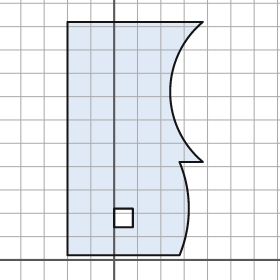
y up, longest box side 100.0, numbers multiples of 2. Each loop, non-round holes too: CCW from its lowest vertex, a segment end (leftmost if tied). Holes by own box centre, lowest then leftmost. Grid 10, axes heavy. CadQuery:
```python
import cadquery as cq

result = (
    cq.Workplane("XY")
    .moveTo(-20.0, 2.0)
    .lineTo(28.0, 2.0)
    .threePointArc((32.0, 22.0), (28.0, 42.0))
    .lineTo(38.0, 42.0)
    .threePointArc((24.0, 72.0), (38.0, 102.0))
    .lineTo(-20.0, 102.0)
    .close()
    .moveTo(0.0, 14.0)
    .lineTo(8.0, 14.0)
    .lineTo(8.0, 22.0)
    .lineTo(0.0, 22.0)
    .close()
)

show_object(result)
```